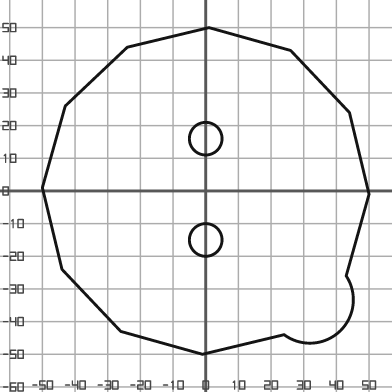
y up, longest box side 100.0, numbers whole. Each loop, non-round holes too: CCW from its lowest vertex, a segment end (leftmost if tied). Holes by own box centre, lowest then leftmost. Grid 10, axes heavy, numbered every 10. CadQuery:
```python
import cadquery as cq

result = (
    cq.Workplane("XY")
    .moveTo(-1.0, -50.0)
    .lineTo(24.0, -44.0)
    .threePointArc((41.0, -43.0), (43.0, -26.0))
    .lineTo(50.0, -1.0)
    .lineTo(44.0, 24.0)
    .lineTo(26.0, 43.0)
    .lineTo(1.0, 50.0)
    .lineTo(-24.0, 44.0)
    .lineTo(-43.0, 26.0)
    .lineTo(-50.0, 1.0)
    .lineTo(-44.0, -24.0)
    .lineTo(-26.0, -43.0)
    .close()
    .moveTo(0.0, -15.0)
    .circle(5.0)
    .moveTo(0.0, 16.0)
    .circle(5.0)
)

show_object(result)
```